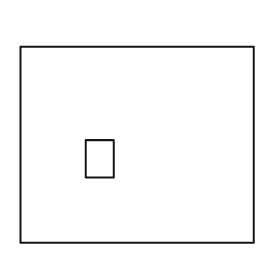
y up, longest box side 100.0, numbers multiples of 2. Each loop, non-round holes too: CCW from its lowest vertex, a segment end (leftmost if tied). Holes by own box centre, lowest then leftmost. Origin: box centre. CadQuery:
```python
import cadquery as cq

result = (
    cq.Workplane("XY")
    .moveTo(-50.0, -42.0)
    .lineTo(50.0, -42.0)
    .lineTo(50.0, 42.0)
    .lineTo(-50.0, 42.0)
    .close()
    .moveTo(-22.0, -14.0)
    .lineTo(-10.0, -14.0)
    .lineTo(-10.0, 2.0)
    .lineTo(-22.0, 2.0)
    .close()
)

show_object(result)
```